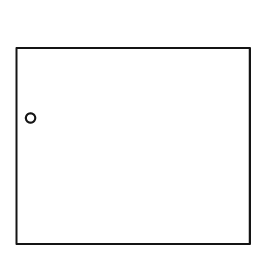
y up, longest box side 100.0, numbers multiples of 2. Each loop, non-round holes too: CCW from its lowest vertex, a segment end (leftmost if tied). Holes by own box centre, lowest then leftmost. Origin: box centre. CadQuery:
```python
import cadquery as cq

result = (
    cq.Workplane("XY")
    .moveTo(-50.0, -42.0)
    .lineTo(50.0, -42.0)
    .lineTo(50.0, 42.0)
    .lineTo(-50.0, 42.0)
    .close()
    .moveTo(-44.0, 12.0)
    .circle(2.0)
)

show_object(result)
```